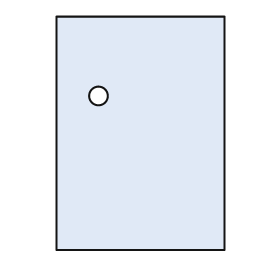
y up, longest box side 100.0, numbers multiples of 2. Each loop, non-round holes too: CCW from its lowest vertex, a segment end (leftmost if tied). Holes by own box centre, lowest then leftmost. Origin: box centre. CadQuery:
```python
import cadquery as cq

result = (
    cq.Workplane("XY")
    .moveTo(-36.0, -50.0)
    .lineTo(36.0, -50.0)
    .lineTo(36.0, 50.0)
    .lineTo(-36.0, 50.0)
    .close()
    .moveTo(-18.0, 16.0)
    .circle(4.0)
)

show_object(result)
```